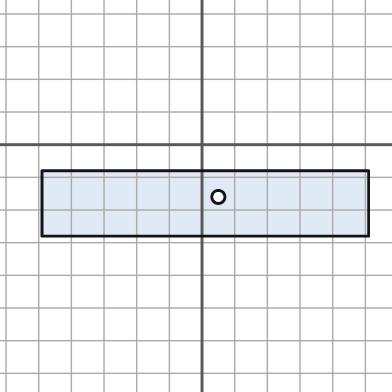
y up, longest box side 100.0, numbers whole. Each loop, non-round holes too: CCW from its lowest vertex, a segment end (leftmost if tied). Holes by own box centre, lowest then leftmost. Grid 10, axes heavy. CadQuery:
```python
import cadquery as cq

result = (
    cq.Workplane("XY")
    .moveTo(-49.0, -28.0)
    .lineTo(51.0, -28.0)
    .lineTo(51.0, -8.0)
    .lineTo(-49.0, -8.0)
    .close()
    .moveTo(5.0, -16.0)
    .circle(2.0)
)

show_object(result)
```